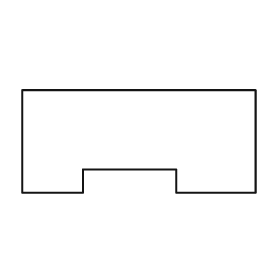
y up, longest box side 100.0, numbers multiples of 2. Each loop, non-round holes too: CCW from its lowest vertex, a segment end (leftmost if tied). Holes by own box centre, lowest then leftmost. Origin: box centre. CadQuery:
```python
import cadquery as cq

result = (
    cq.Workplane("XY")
    .moveTo(-50.0, -22.0)
    .lineTo(-24.0, -22.0)
    .lineTo(-24.0, -12.0)
    .lineTo(16.0, -12.0)
    .lineTo(16.0, -22.0)
    .lineTo(50.0, -22.0)
    .lineTo(50.0, 22.0)
    .lineTo(-50.0, 22.0)
    .close()
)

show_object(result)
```